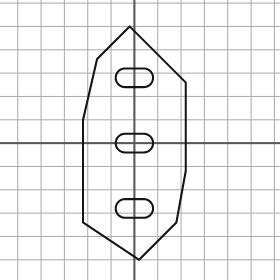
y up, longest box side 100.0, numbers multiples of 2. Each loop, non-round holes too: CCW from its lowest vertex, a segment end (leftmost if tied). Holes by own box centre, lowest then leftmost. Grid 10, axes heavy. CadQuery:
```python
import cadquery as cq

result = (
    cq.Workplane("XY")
    .moveTo(2.0, -50.0)
    .lineTo(18.0, -34.0)
    .lineTo(22.0, -12.0)
    .lineTo(22.0, 26.0)
    .lineTo(-2.0, 50.0)
    .lineTo(-16.0, 36.0)
    .lineTo(-22.0, 10.0)
    .lineTo(-22.0, -34.0)
    .close()
    .moveTo(-4.0, -32.0)
    .lineTo(4.0, -32.0)
    .threePointArc((8.0, -28.0), (4.0, -24.0))
    .lineTo(-4.0, -24.0)
    .threePointArc((-8.0, -28.0), (-4.0, -32.0))
    .close()
    .moveTo(-4.0, -4.0)
    .lineTo(4.0, -4.0)
    .threePointArc((8.0, 0.0), (4.0, 4.0))
    .lineTo(-4.0, 4.0)
    .threePointArc((-8.0, 0.0), (-4.0, -4.0))
    .close()
    .moveTo(-4.0, 24.0)
    .lineTo(4.0, 24.0)
    .threePointArc((8.0, 28.0), (4.0, 32.0))
    .lineTo(-4.0, 32.0)
    .threePointArc((-8.0, 28.0), (-4.0, 24.0))
    .close()
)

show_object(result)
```